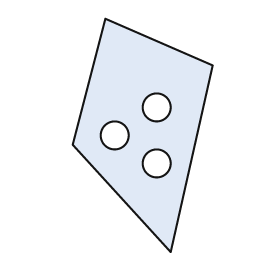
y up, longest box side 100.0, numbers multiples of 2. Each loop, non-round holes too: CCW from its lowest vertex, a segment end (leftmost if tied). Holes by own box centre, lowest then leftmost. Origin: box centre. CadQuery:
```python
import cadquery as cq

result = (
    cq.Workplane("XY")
    .moveTo(12.0, -50.0)
    .lineTo(30.0, 30.0)
    .lineTo(-16.0, 50.0)
    .lineTo(-30.0, -4.0)
    .close()
    .moveTo(6.0, -12.0)
    .circle(6.0)
    .moveTo(-12.0, 0.0)
    .circle(6.0)
    .moveTo(6.0, 12.0)
    .circle(6.0)
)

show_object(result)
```